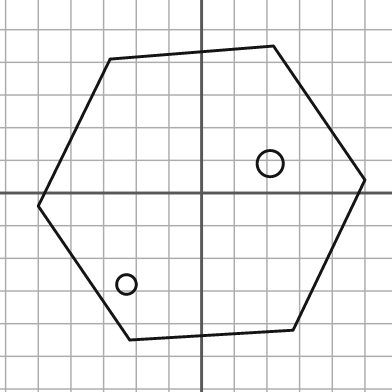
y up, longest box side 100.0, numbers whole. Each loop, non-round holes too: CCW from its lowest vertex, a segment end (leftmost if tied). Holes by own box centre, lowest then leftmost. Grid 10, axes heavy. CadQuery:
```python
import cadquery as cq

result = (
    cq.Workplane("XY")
    .moveTo(-22.0, -45.0)
    .lineTo(28.0, -42.0)
    .lineTo(50.0, 4.0)
    .lineTo(22.0, 45.0)
    .lineTo(-28.0, 41.0)
    .lineTo(-50.0, -4.0)
    .close()
    .moveTo(-23.0, -28.0)
    .circle(3.0)
    .moveTo(21.0, 9.0)
    .circle(4.0)
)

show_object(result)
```